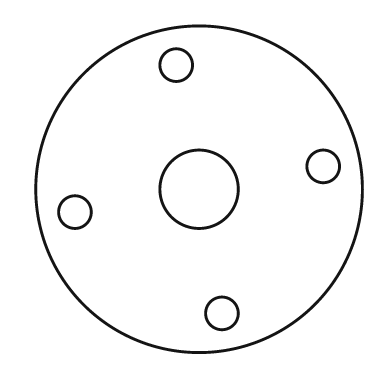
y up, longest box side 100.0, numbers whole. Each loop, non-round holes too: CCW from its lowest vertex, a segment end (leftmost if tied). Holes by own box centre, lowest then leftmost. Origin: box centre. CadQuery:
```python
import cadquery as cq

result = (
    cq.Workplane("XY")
    .moveTo(0.0, 0.0)
    .circle(50.0)
    .moveTo(7.0, -38.0)
    .circle(5.0)
    .moveTo(-38.0, -7.0)
    .circle(5.0)
    .moveTo(0.0, 0.0)
    .circle(12.0)
    .moveTo(38.0, 7.0)
    .circle(5.0)
    .moveTo(-7.0, 38.0)
    .circle(5.0)
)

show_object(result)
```